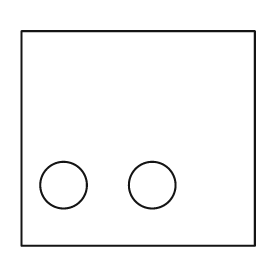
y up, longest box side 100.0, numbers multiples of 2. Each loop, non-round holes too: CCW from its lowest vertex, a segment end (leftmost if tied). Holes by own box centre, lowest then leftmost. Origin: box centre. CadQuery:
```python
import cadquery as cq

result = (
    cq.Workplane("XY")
    .moveTo(-50.0, -46.0)
    .lineTo(50.0, -46.0)
    .lineTo(50.0, 46.0)
    .lineTo(-50.0, 46.0)
    .close()
    .moveTo(-32.0, -20.0)
    .circle(10.0)
    .moveTo(6.0, -20.0)
    .circle(10.0)
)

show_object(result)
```